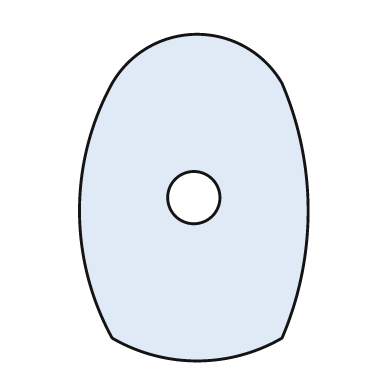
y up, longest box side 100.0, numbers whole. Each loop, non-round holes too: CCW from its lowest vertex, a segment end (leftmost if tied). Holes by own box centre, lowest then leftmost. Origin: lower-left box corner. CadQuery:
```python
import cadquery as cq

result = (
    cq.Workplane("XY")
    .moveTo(10.0, 7.0)
    .threePointArc((36.0, 0.0), (62.0, 7.0))
    .threePointArc((70.0, 46.0), (62.0, 85.0))
    .threePointArc((36.0, 100.0), (10.0, 85.0))
    .threePointArc((0.0, 46.0), (10.0, 7.0))
    .close()
    .moveTo(35.0, 50.0)
    .circle(8.0)
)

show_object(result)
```